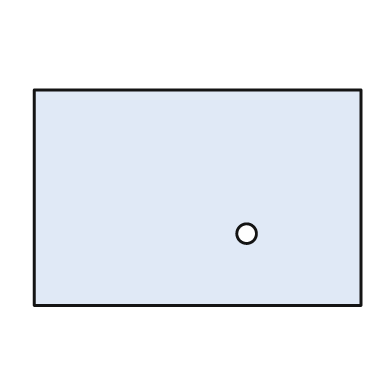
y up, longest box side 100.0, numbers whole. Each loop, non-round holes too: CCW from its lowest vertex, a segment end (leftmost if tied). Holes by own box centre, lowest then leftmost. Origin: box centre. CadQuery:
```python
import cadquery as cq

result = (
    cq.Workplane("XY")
    .moveTo(-50.0, -33.0)
    .lineTo(50.0, -33.0)
    .lineTo(50.0, 33.0)
    .lineTo(-50.0, 33.0)
    .close()
    .moveTo(15.0, -11.0)
    .circle(3.0)
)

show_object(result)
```